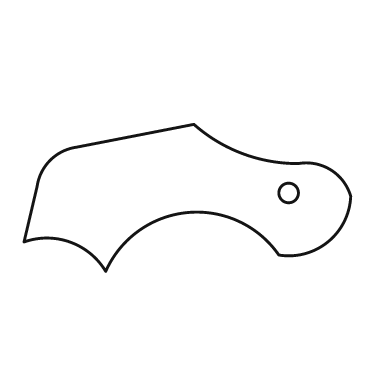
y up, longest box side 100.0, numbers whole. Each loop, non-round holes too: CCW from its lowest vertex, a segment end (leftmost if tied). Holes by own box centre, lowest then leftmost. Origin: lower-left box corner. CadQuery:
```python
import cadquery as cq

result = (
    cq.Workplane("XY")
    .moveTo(25.0, 0.0)
    .threePointArc((50.0, 18.0), (78.0, 5.0))
    .threePointArc((93.0, 9.0), (100.0, 23.0))
    .threePointArc((94.0, 31.0), (84.0, 33.0))
    .threePointArc((67.0, 36.0), (52.0, 45.0))
    .lineTo(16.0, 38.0)
    .threePointArc((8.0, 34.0), (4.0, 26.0))
    .lineTo(0.0, 9.0)
    .threePointArc((14.0, 9.0), (25.0, 0.0))
    .close()
    .moveTo(81.0, 24.0)
    .circle(3.0)
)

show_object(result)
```